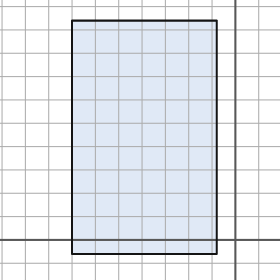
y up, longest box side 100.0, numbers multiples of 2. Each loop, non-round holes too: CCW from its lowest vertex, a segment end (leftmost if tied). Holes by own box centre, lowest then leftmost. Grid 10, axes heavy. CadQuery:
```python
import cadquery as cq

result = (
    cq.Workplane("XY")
    .moveTo(-70.0, -6.0)
    .lineTo(-8.0, -6.0)
    .lineTo(-8.0, 94.0)
    .lineTo(-70.0, 94.0)
    .close()
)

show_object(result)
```